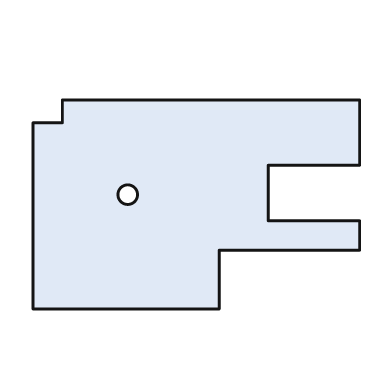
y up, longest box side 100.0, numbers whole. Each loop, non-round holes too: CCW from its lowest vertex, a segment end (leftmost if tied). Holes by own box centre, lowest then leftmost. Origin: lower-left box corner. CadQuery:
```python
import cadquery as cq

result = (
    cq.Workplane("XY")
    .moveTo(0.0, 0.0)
    .lineTo(57.0, 0.0)
    .lineTo(57.0, 18.0)
    .lineTo(100.0, 18.0)
    .lineTo(100.0, 27.0)
    .lineTo(72.0, 27.0)
    .lineTo(72.0, 44.0)
    .lineTo(100.0, 44.0)
    .lineTo(100.0, 64.0)
    .lineTo(9.0, 64.0)
    .lineTo(9.0, 57.0)
    .lineTo(0.0, 57.0)
    .close()
    .moveTo(29.0, 35.0)
    .circle(3.0)
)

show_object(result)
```